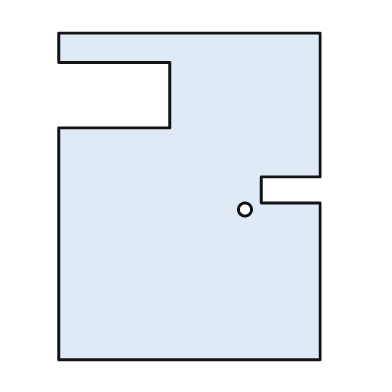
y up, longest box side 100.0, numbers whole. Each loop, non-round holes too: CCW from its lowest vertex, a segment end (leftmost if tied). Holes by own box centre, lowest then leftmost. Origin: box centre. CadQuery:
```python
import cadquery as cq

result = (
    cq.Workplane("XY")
    .moveTo(-40.0, -50.0)
    .lineTo(40.0, -50.0)
    .lineTo(40.0, -2.0)
    .lineTo(22.0, -2.0)
    .lineTo(22.0, 6.0)
    .lineTo(40.0, 6.0)
    .lineTo(40.0, 50.0)
    .lineTo(-40.0, 50.0)
    .lineTo(-40.0, 41.0)
    .lineTo(-6.0, 41.0)
    .lineTo(-6.0, 21.0)
    .lineTo(-40.0, 21.0)
    .close()
    .moveTo(17.0, -4.0)
    .circle(2.0)
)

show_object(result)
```